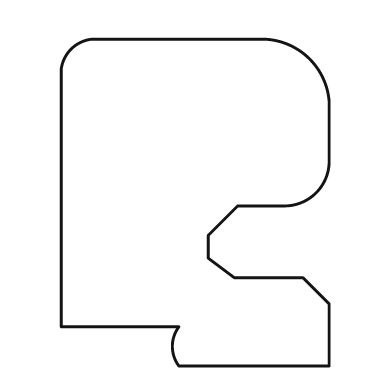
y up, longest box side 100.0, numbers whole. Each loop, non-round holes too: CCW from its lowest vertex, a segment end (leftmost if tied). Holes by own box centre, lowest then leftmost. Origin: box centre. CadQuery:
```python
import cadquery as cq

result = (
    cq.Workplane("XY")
    .moveTo(-5.0, -50.0)
    .lineTo(41.0, -50.0)
    .lineTo(41.0, -31.0)
    .lineTo(33.0, -23.0)
    .lineTo(12.0, -23.0)
    .lineTo(4.0, -17.0)
    .lineTo(4.0, -10.0)
    .lineTo(13.0, -1.0)
    .lineTo(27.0, -1.0)
    .threePointArc((37.0, 3.0), (41.0, 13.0))
    .lineTo(41.0, 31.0)
    .threePointArc((35.0, 44.0), (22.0, 50.0))
    .lineTo(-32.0, 50.0)
    .threePointArc((-38.0, 47.0), (-41.0, 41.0))
    .lineTo(-41.0, -38.0)
    .lineTo(-5.0, -38.0)
    .threePointArc((-7.0, -44.0), (-5.0, -50.0))
    .close()
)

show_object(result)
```